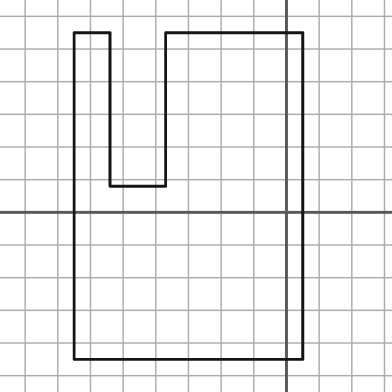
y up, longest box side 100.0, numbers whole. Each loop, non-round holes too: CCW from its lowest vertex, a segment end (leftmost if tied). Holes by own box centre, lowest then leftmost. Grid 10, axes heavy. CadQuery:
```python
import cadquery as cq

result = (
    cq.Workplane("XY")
    .moveTo(-65.0, -45.0)
    .lineTo(5.0, -45.0)
    .lineTo(5.0, 55.0)
    .lineTo(-37.0, 55.0)
    .lineTo(-37.0, 8.0)
    .lineTo(-54.0, 8.0)
    .lineTo(-54.0, 55.0)
    .lineTo(-65.0, 55.0)
    .close()
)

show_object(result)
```